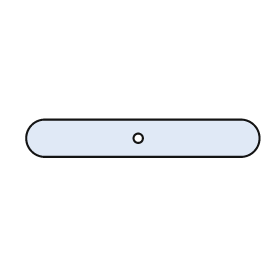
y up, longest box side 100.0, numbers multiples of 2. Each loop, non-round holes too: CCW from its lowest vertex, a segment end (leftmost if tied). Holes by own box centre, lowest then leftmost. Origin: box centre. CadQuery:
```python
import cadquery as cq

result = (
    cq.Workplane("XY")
    .moveTo(-42.0, -8.0)
    .lineTo(42.0, -8.0)
    .threePointArc((50.0, 0.0), (42.0, 8.0))
    .lineTo(-42.0, 8.0)
    .threePointArc((-50.0, 0.0), (-42.0, -8.0))
    .close()
    .moveTo(-2.0, 0.0)
    .circle(2.0)
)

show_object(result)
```